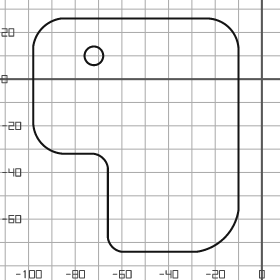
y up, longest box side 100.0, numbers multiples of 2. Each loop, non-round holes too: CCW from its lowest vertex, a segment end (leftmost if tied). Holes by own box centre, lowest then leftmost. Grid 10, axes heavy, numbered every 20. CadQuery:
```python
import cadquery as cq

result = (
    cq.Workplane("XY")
    .moveTo(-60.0, -74.0)
    .lineTo(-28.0, -74.0)
    .threePointArc((-16.0, -68.0), (-10.0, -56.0))
    .lineTo(-10.0, 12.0)
    .threePointArc((-14.0, 22.0), (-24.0, 26.0))
    .lineTo(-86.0, 26.0)
    .threePointArc((-94.0, 22.0), (-98.0, 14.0))
    .lineTo(-98.0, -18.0)
    .threePointArc((-94.0, -28.0), (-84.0, -32.0))
    .lineTo(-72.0, -32.0)
    .threePointArc((-68.0, -34.0), (-66.0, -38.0))
    .lineTo(-66.0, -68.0)
    .threePointArc((-64.0, -72.0), (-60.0, -74.0))
    .close()
    .moveTo(-72.0, 10.0)
    .circle(4.0)
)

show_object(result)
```